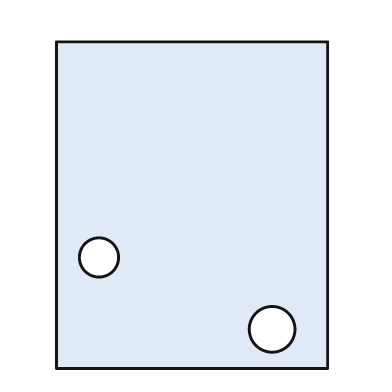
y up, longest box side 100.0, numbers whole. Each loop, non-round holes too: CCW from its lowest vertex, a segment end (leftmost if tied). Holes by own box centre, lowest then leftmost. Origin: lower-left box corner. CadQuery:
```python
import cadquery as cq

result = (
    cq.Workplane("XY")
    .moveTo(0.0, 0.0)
    .lineTo(83.0, 0.0)
    .lineTo(83.0, 100.0)
    .lineTo(0.0, 100.0)
    .close()
    .moveTo(66.0, 12.0)
    .circle(7.0)
    .moveTo(13.0, 34.0)
    .circle(6.0)
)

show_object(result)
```